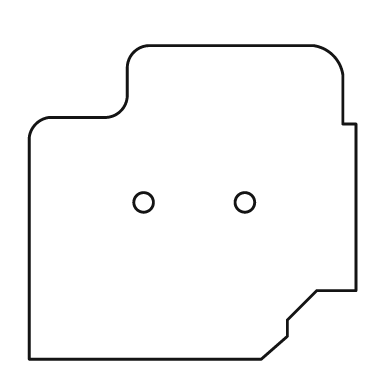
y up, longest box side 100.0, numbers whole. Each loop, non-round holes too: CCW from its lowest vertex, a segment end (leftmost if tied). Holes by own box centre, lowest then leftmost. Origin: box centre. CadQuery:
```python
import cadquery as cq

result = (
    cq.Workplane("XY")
    .moveTo(-50.0, -48.0)
    .lineTo(21.0, -48.0)
    .lineTo(29.0, -41.0)
    .lineTo(29.0, -36.0)
    .lineTo(38.0, -27.0)
    .lineTo(50.0, -27.0)
    .lineTo(50.0, 24.0)
    .lineTo(46.0, 24.0)
    .lineTo(46.0, 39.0)
    .threePointArc((43.0, 45.0), (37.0, 48.0))
    .lineTo(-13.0, 48.0)
    .threePointArc((-18.0, 46.0), (-20.0, 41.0))
    .lineTo(-20.0, 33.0)
    .threePointArc((-22.0, 28.0), (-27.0, 26.0))
    .lineTo(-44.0, 26.0)
    .threePointArc((-48.0, 24.0), (-50.0, 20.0))
    .close()
    .moveTo(-15.0, 0.0)
    .circle(3.0)
    .moveTo(16.0, 0.0)
    .circle(3.0)
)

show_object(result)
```